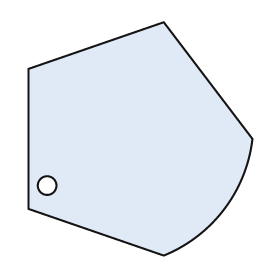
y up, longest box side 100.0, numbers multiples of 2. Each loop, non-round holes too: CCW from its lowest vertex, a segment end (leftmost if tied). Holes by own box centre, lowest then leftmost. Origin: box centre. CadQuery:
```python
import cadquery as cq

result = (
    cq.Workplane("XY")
    .moveTo(10.0, -50.0)
    .threePointArc((36.0, -30.0), (48.0, 0.0))
    .lineTo(10.0, 50.0)
    .lineTo(-48.0, 30.0)
    .lineTo(-48.0, -30.0)
    .close()
    .moveTo(-40.0, -20.0)
    .circle(4.0)
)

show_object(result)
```